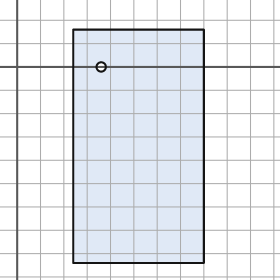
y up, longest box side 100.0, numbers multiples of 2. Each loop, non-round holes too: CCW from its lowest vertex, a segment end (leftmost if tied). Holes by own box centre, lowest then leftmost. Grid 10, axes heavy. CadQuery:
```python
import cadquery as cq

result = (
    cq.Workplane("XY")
    .moveTo(24.0, -84.0)
    .lineTo(80.0, -84.0)
    .lineTo(80.0, 16.0)
    .lineTo(24.0, 16.0)
    .close()
    .moveTo(36.0, 0.0)
    .circle(2.0)
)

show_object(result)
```